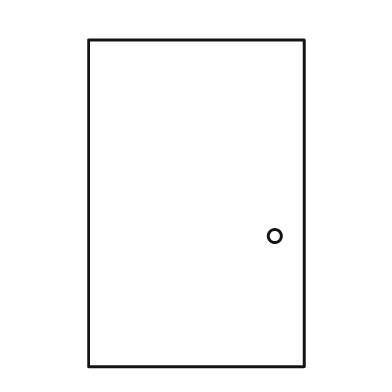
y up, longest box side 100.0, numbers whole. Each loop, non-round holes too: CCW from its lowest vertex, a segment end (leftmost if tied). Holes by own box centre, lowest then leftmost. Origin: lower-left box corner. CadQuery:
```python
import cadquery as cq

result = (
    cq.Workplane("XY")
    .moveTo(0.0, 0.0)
    .lineTo(66.0, 0.0)
    .lineTo(66.0, 100.0)
    .lineTo(0.0, 100.0)
    .close()
    .moveTo(57.0, 40.0)
    .circle(2.0)
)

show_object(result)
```